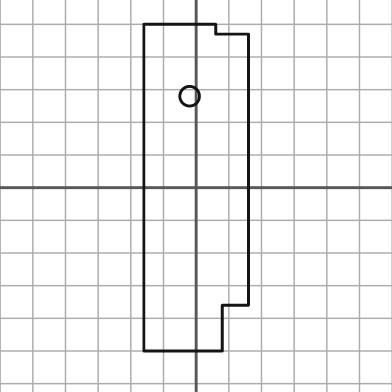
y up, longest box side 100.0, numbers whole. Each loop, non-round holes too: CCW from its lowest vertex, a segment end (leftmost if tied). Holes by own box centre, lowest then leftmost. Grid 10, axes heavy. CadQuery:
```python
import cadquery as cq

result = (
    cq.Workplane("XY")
    .moveTo(-16.0, -50.0)
    .lineTo(8.0, -50.0)
    .lineTo(8.0, -36.0)
    .lineTo(16.0, -36.0)
    .lineTo(16.0, 47.0)
    .lineTo(6.0, 47.0)
    .lineTo(6.0, 50.0)
    .lineTo(-16.0, 50.0)
    .close()
    .moveTo(-2.0, 28.0)
    .circle(3.0)
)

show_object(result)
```